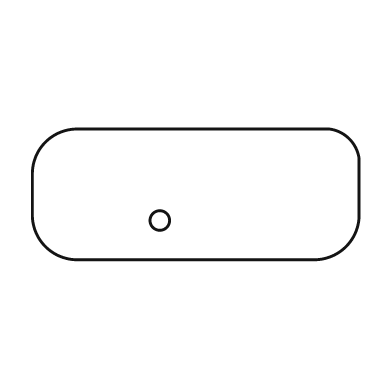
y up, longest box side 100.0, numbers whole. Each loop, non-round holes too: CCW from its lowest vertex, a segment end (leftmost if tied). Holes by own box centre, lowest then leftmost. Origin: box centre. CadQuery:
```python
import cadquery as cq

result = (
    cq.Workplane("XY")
    .moveTo(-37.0, -20.0)
    .lineTo(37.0, -20.0)
    .threePointArc((46.0, -16.0), (50.0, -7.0))
    .lineTo(50.0, 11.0)
    .threePointArc((47.0, 17.0), (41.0, 20.0))
    .lineTo(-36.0, 20.0)
    .threePointArc((-46.0, 16.0), (-50.0, 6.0))
    .lineTo(-50.0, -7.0)
    .threePointArc((-46.0, -16.0), (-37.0, -20.0))
    .close()
    .moveTo(-11.0, -8.0)
    .circle(3.0)
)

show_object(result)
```